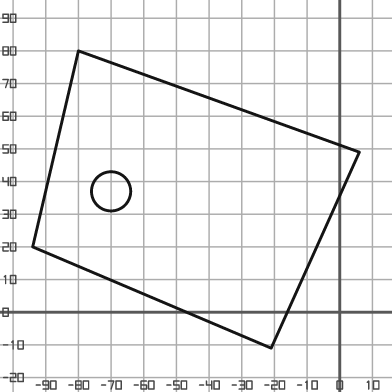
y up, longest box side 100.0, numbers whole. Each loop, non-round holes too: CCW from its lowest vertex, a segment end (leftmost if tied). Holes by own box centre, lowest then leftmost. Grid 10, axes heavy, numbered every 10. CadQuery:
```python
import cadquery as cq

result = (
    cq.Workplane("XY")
    .moveTo(-21.0, -11.0)
    .lineTo(6.0, 49.0)
    .lineTo(-80.0, 80.0)
    .lineTo(-94.0, 20.0)
    .close()
    .moveTo(-70.0, 37.0)
    .circle(6.0)
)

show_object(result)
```